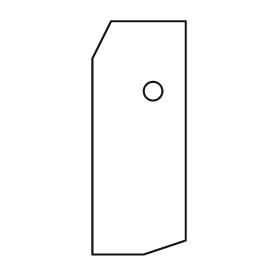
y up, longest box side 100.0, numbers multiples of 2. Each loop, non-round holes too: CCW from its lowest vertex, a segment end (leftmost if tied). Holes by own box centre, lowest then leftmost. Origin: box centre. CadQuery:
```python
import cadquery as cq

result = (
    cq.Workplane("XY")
    .moveTo(-20.0, -50.0)
    .lineTo(2.0, -50.0)
    .lineTo(20.0, -44.0)
    .lineTo(20.0, 50.0)
    .lineTo(-12.0, 50.0)
    .lineTo(-20.0, 34.0)
    .close()
    .moveTo(6.0, 20.0)
    .circle(4.0)
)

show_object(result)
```